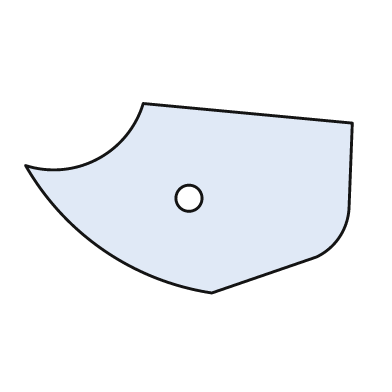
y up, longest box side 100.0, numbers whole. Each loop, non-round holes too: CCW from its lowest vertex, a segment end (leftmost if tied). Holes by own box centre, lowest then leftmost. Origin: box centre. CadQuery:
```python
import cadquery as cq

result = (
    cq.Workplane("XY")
    .moveTo(7.0, -29.0)
    .lineTo(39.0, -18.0)
    .threePointArc((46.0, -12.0), (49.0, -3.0))
    .lineTo(50.0, 23.0)
    .lineTo(-14.0, 29.0)
    .threePointArc((-28.0, 12.0), (-50.0, 10.0))
    .threePointArc((-26.0, -16.0), (7.0, -29.0))
    .close()
    .moveTo(0.0, 0.0)
    .circle(4.0)
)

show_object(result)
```